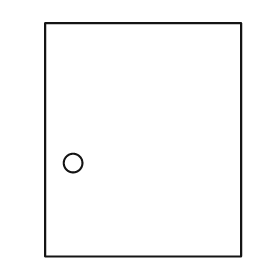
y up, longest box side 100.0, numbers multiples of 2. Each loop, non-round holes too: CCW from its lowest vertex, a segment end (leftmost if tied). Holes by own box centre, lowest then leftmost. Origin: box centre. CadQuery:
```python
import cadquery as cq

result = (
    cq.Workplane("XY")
    .moveTo(-42.0, -50.0)
    .lineTo(42.0, -50.0)
    .lineTo(42.0, 50.0)
    .lineTo(-42.0, 50.0)
    .close()
    .moveTo(-30.0, -10.0)
    .circle(4.0)
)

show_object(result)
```